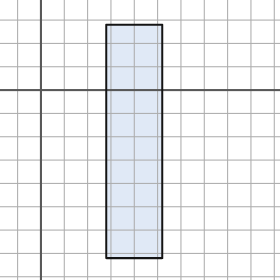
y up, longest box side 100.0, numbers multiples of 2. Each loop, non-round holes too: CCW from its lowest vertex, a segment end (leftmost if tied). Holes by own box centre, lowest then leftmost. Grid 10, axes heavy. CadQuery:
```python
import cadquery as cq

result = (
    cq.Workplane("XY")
    .moveTo(28.0, -72.0)
    .lineTo(52.0, -72.0)
    .lineTo(52.0, 28.0)
    .lineTo(28.0, 28.0)
    .close()
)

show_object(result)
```